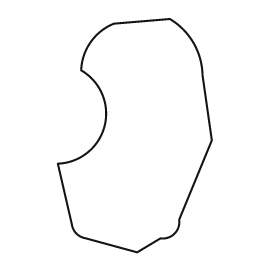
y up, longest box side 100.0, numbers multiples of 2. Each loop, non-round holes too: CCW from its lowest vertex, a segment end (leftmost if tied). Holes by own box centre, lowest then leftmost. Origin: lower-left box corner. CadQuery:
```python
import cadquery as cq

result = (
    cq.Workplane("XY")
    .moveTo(34.0, 0.0)
    .lineTo(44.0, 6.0)
    .threePointArc((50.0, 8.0), (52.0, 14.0))
    .lineTo(66.0, 48.0)
    .lineTo(62.0, 76.0)
    .threePointArc((58.0, 90.0), (48.0, 100.0))
    .lineTo(24.0, 98.0)
    .threePointArc((14.0, 90.0), (10.0, 78.0))
    .threePointArc((20.0, 54.0), (0.0, 38.0))
    .lineTo(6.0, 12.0)
    .threePointArc((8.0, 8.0), (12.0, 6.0))
    .close()
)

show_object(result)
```